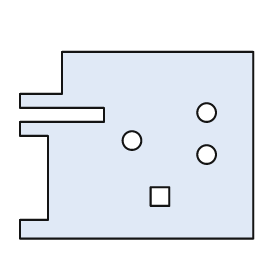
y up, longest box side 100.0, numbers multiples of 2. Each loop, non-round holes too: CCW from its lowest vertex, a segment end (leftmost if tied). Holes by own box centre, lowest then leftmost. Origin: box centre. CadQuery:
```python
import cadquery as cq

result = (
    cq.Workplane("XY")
    .moveTo(-50.0, -40.0)
    .lineTo(50.0, -40.0)
    .lineTo(50.0, 40.0)
    .lineTo(-32.0, 40.0)
    .lineTo(-32.0, 22.0)
    .lineTo(-50.0, 22.0)
    .lineTo(-50.0, 16.0)
    .lineTo(-14.0, 16.0)
    .lineTo(-14.0, 10.0)
    .lineTo(-50.0, 10.0)
    .lineTo(-50.0, 4.0)
    .lineTo(-38.0, 4.0)
    .lineTo(-38.0, -32.0)
    .lineTo(-50.0, -32.0)
    .close()
    .moveTo(6.0, -26.0)
    .lineTo(14.0, -26.0)
    .lineTo(14.0, -18.0)
    .lineTo(6.0, -18.0)
    .close()
    .moveTo(30.0, -4.0)
    .circle(4.0)
    .moveTo(-2.0, 2.0)
    .circle(4.0)
    .moveTo(30.0, 14.0)
    .circle(4.0)
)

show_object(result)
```